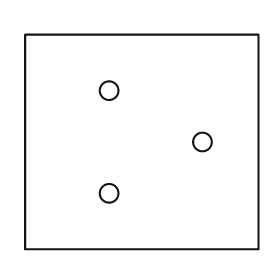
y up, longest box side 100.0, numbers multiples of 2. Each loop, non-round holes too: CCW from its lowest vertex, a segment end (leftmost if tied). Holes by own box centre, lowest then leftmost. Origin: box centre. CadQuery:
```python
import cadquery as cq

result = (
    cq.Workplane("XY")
    .moveTo(-50.0, -46.0)
    .lineTo(50.0, -46.0)
    .lineTo(50.0, 46.0)
    .lineTo(-50.0, 46.0)
    .close()
    .moveTo(-14.0, -22.0)
    .circle(4.0)
    .moveTo(26.0, 0.0)
    .circle(4.0)
    .moveTo(-14.0, 22.0)
    .circle(4.0)
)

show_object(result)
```